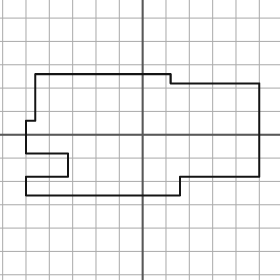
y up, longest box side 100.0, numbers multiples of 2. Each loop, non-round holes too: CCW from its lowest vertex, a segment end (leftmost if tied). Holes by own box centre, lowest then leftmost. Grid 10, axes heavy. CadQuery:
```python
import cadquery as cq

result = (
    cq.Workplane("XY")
    .moveTo(-50.0, -26.0)
    .lineTo(16.0, -26.0)
    .lineTo(16.0, -18.0)
    .lineTo(50.0, -18.0)
    .lineTo(50.0, 22.0)
    .lineTo(12.0, 22.0)
    .lineTo(12.0, 26.0)
    .lineTo(-46.0, 26.0)
    .lineTo(-46.0, 6.0)
    .lineTo(-50.0, 6.0)
    .lineTo(-50.0, -8.0)
    .lineTo(-32.0, -8.0)
    .lineTo(-32.0, -18.0)
    .lineTo(-50.0, -18.0)
    .close()
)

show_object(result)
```